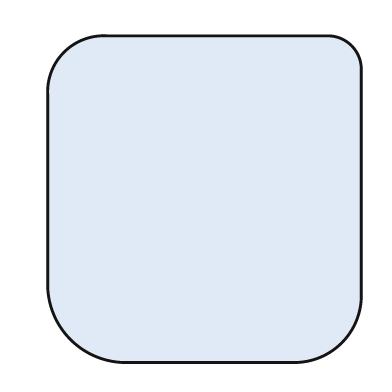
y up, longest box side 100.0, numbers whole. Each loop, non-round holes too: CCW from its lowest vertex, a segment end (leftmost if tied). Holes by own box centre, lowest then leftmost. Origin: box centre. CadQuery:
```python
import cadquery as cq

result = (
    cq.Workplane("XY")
    .moveTo(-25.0, -50.0)
    .lineTo(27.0, -50.0)
    .threePointArc((42.0, -44.0), (48.0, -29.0))
    .lineTo(48.0, 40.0)
    .threePointArc((45.0, 47.0), (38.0, 50.0))
    .lineTo(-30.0, 50.0)
    .threePointArc((-43.0, 45.0), (-48.0, 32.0))
    .lineTo(-48.0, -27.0)
    .threePointArc((-41.0, -43.0), (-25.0, -50.0))
    .close()
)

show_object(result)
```